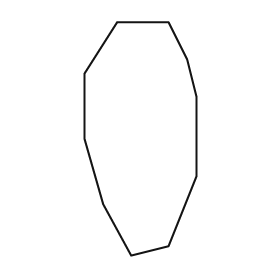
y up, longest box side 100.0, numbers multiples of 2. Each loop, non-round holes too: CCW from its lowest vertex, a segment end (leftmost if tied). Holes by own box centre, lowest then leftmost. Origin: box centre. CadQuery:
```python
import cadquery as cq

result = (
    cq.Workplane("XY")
    .moveTo(-4.0, -50.0)
    .lineTo(12.0, -46.0)
    .lineTo(24.0, -16.0)
    .lineTo(24.0, 18.0)
    .lineTo(20.0, 34.0)
    .lineTo(12.0, 50.0)
    .lineTo(-10.0, 50.0)
    .lineTo(-24.0, 28.0)
    .lineTo(-24.0, 0.0)
    .lineTo(-16.0, -28.0)
    .close()
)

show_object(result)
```